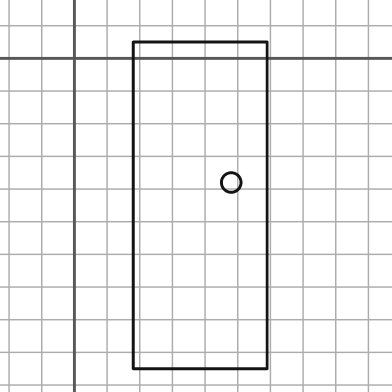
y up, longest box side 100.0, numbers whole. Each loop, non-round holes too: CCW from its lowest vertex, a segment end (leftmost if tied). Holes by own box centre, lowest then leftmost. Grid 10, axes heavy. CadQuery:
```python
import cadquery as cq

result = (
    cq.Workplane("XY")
    .moveTo(18.0, -95.0)
    .lineTo(59.0, -95.0)
    .lineTo(59.0, 5.0)
    .lineTo(18.0, 5.0)
    .close()
    .moveTo(48.0, -38.0)
    .circle(3.0)
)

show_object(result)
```